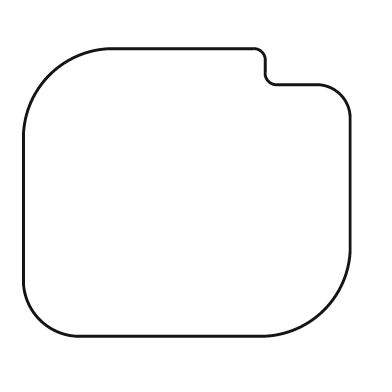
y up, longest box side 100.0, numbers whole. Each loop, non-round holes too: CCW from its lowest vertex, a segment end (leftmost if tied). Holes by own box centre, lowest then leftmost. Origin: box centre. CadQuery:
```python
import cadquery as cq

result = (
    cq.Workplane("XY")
    .moveTo(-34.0, -44.0)
    .lineTo(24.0, -44.0)
    .threePointArc((42.0, -36.0), (50.0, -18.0))
    .lineTo(50.0, 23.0)
    .threePointArc((47.0, 30.0), (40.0, 33.0))
    .lineTo(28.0, 33.0)
    .threePointArc((25.0, 34.0), (24.0, 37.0))
    .lineTo(24.0, 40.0)
    .threePointArc((23.0, 43.0), (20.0, 44.0))
    .lineTo(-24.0, 44.0)
    .threePointArc((-42.0, 36.0), (-50.0, 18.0))
    .lineTo(-50.0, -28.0)
    .threePointArc((-45.0, -39.0), (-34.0, -44.0))
    .close()
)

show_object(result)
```